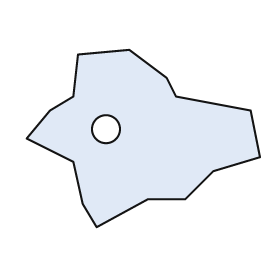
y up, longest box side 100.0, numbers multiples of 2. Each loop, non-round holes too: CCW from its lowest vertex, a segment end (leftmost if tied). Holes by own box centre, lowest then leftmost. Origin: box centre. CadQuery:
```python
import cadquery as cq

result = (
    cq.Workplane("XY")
    .moveTo(-20.0, -38.0)
    .lineTo(2.0, -26.0)
    .lineTo(18.0, -26.0)
    .lineTo(30.0, -14.0)
    .lineTo(50.0, -8.0)
    .lineTo(46.0, 12.0)
    .lineTo(14.0, 18.0)
    .lineTo(10.0, 26.0)
    .lineTo(-6.0, 38.0)
    .lineTo(-28.0, 36.0)
    .lineTo(-30.0, 18.0)
    .lineTo(-40.0, 12.0)
    .lineTo(-50.0, 0.0)
    .lineTo(-30.0, -10.0)
    .lineTo(-26.0, -28.0)
    .close()
    .moveTo(-16.0, 4.0)
    .circle(6.0)
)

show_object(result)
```